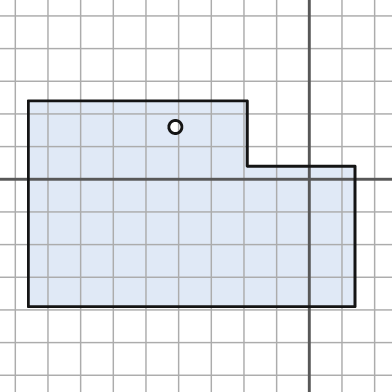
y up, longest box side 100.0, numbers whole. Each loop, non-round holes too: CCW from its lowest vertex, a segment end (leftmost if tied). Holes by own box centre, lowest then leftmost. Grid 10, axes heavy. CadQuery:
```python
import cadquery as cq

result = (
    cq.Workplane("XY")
    .moveTo(-86.0, -39.0)
    .lineTo(14.0, -39.0)
    .lineTo(14.0, 4.0)
    .lineTo(-19.0, 4.0)
    .lineTo(-19.0, 24.0)
    .lineTo(-86.0, 24.0)
    .close()
    .moveTo(-41.0, 16.0)
    .circle(2.0)
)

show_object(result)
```